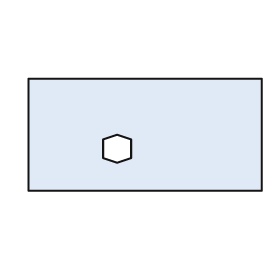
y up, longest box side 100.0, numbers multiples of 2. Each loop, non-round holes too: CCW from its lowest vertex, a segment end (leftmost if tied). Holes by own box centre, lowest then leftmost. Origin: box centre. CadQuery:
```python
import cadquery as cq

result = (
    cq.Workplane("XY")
    .moveTo(-50.0, -24.0)
    .lineTo(50.0, -24.0)
    .lineTo(50.0, 24.0)
    .lineTo(-50.0, 24.0)
    .close()
    .moveTo(-12.0, -12.0)
    .lineTo(-6.0, -10.0)
    .lineTo(-6.0, -2.0)
    .lineTo(-12.0, 0.0)
    .lineTo(-18.0, -2.0)
    .lineTo(-18.0, -10.0)
    .close()
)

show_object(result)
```